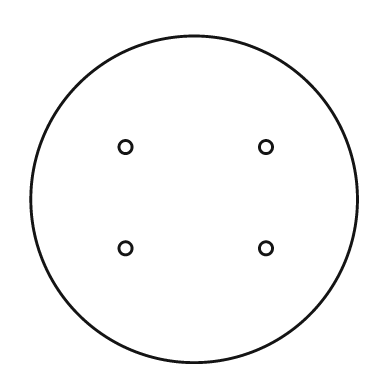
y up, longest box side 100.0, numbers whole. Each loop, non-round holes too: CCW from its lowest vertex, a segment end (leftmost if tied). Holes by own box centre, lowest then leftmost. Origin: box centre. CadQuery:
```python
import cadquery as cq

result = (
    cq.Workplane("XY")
    .moveTo(0.0, 0.0)
    .circle(50.0)
    .moveTo(-21.0, -15.0)
    .circle(2.0)
    .moveTo(22.0, -15.0)
    .circle(2.0)
    .moveTo(-21.0, 16.0)
    .circle(2.0)
    .moveTo(22.0, 16.0)
    .circle(2.0)
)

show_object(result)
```